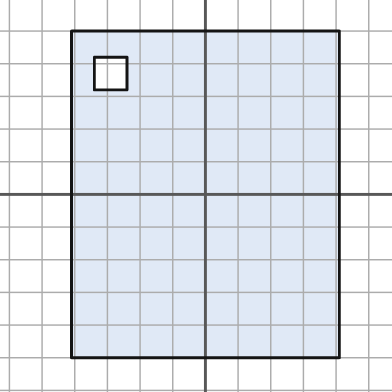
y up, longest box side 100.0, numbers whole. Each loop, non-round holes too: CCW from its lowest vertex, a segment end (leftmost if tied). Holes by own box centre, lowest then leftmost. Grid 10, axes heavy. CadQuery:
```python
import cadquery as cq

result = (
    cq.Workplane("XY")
    .moveTo(-41.0, -50.0)
    .lineTo(41.0, -50.0)
    .lineTo(41.0, 50.0)
    .lineTo(-41.0, 50.0)
    .close()
    .moveTo(-34.0, 32.0)
    .lineTo(-24.0, 32.0)
    .lineTo(-24.0, 42.0)
    .lineTo(-34.0, 42.0)
    .close()
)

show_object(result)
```